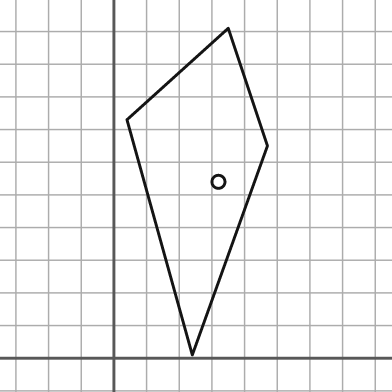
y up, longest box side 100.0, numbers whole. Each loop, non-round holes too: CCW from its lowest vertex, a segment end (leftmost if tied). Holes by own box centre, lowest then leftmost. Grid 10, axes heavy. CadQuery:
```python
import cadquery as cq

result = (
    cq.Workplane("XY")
    .moveTo(24.0, 1.0)
    .lineTo(47.0, 65.0)
    .lineTo(35.0, 101.0)
    .lineTo(4.0, 73.0)
    .close()
    .moveTo(32.0, 54.0)
    .circle(2.0)
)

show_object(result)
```